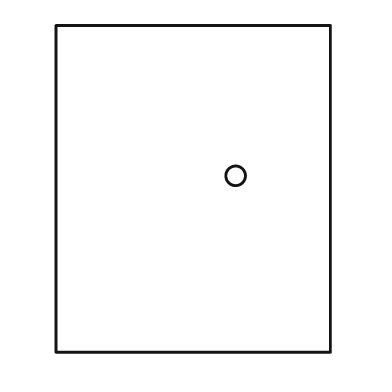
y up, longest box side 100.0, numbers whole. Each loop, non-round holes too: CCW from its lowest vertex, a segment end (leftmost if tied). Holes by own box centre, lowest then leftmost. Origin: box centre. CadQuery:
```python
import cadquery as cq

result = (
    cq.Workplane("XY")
    .moveTo(-42.0, -50.0)
    .lineTo(42.0, -50.0)
    .lineTo(42.0, 50.0)
    .lineTo(-42.0, 50.0)
    .close()
    .moveTo(13.0, 4.0)
    .circle(3.0)
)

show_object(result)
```